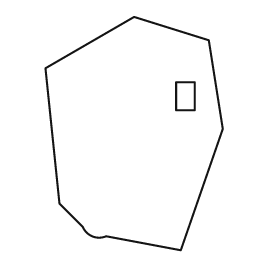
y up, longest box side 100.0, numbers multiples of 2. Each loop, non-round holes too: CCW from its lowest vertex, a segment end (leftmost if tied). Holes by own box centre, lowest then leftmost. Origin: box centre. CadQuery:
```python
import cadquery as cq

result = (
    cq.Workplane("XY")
    .moveTo(20.0, -50.0)
    .lineTo(38.0, 2.0)
    .lineTo(32.0, 40.0)
    .lineTo(0.0, 50.0)
    .lineTo(-38.0, 28.0)
    .lineTo(-32.0, -30.0)
    .lineTo(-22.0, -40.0)
    .threePointArc((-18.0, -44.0), (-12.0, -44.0))
    .close()
    .moveTo(18.0, 10.0)
    .lineTo(26.0, 10.0)
    .lineTo(26.0, 22.0)
    .lineTo(18.0, 22.0)
    .close()
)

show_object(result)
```